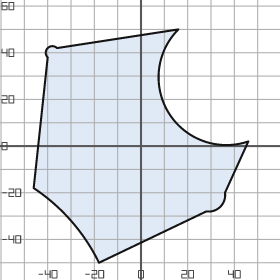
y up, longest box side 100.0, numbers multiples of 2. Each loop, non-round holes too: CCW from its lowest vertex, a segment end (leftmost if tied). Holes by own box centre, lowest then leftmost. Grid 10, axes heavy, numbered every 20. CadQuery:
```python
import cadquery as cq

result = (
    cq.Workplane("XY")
    .moveTo(-18.0, -50.0)
    .lineTo(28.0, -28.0)
    .threePointArc((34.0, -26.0), (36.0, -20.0))
    .lineTo(46.0, 2.0)
    .threePointArc((12.0, 14.0), (16.0, 50.0))
    .lineTo(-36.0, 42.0)
    .threePointArc((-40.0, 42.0), (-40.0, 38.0))
    .lineTo(-46.0, -18.0)
    .threePointArc((-30.0, -32.0), (-18.0, -50.0))
    .close()
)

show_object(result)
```